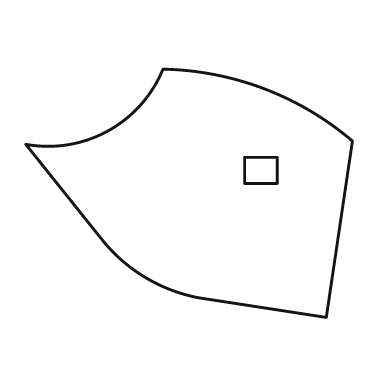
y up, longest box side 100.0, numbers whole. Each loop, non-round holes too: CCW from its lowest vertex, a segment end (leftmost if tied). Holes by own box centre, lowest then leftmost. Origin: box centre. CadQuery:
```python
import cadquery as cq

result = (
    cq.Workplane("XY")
    .moveTo(42.0, -38.0)
    .lineTo(50.0, 16.0)
    .threePointArc((23.0, 32.0), (-8.0, 38.0))
    .threePointArc((-25.0, 19.0), (-50.0, 15.0))
    .lineTo(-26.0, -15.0)
    .threePointArc((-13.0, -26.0), (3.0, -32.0))
    .close()
    .moveTo(17.0, 3.0)
    .lineTo(27.0, 3.0)
    .lineTo(27.0, 11.0)
    .lineTo(17.0, 11.0)
    .close()
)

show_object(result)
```